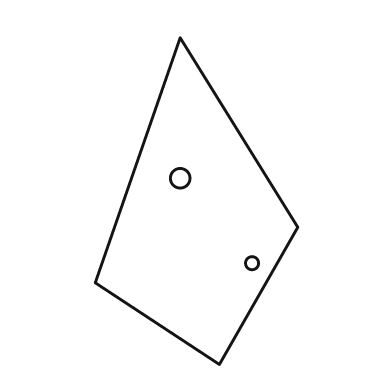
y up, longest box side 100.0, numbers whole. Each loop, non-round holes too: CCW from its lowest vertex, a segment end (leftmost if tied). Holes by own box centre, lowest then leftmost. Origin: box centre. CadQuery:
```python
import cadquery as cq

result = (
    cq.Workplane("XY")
    .moveTo(7.0, -50.0)
    .lineTo(31.0, -8.0)
    .lineTo(-5.0, 50.0)
    .lineTo(-31.0, -25.0)
    .close()
    .moveTo(17.0, -19.0)
    .circle(2.0)
    .moveTo(-5.0, 7.0)
    .circle(3.0)
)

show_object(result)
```